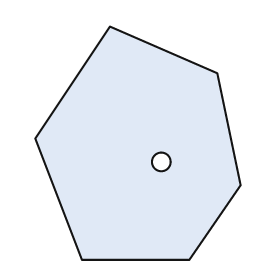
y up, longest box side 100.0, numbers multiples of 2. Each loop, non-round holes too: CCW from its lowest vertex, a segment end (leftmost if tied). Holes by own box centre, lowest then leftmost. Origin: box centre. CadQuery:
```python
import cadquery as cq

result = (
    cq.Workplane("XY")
    .moveTo(-24.0, -50.0)
    .lineTo(22.0, -50.0)
    .lineTo(44.0, -18.0)
    .lineTo(34.0, 30.0)
    .lineTo(-12.0, 50.0)
    .lineTo(-44.0, 2.0)
    .close()
    .moveTo(10.0, -8.0)
    .circle(4.0)
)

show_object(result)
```